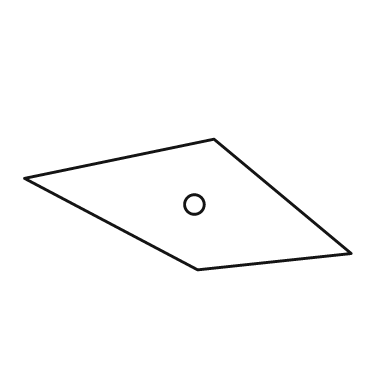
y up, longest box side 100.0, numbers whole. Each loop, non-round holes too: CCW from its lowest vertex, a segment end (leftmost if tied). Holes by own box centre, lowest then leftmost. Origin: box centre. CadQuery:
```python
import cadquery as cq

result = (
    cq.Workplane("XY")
    .moveTo(3.0, -20.0)
    .lineTo(50.0, -15.0)
    .lineTo(8.0, 20.0)
    .lineTo(-50.0, 8.0)
    .close()
    .moveTo(2.0, 0.0)
    .circle(3.0)
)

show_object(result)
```